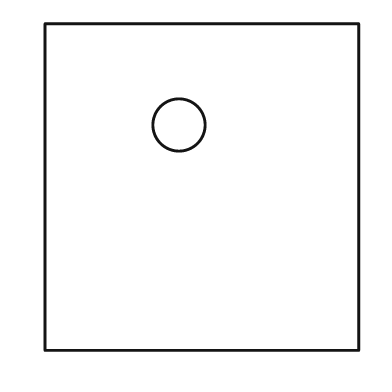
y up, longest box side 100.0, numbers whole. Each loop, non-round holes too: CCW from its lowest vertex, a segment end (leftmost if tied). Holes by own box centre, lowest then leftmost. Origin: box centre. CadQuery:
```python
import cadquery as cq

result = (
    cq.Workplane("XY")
    .moveTo(-48.0, -50.0)
    .lineTo(48.0, -50.0)
    .lineTo(48.0, 50.0)
    .lineTo(-48.0, 50.0)
    .close()
    .moveTo(-7.0, 19.0)
    .circle(8.0)
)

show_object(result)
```